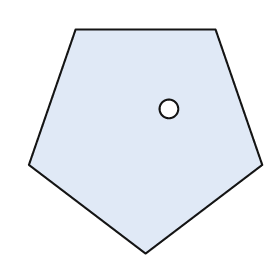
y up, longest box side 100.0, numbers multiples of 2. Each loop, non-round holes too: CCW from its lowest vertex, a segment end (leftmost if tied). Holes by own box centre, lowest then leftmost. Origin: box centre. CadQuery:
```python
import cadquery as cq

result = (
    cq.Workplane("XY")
    .moveTo(0.0, -48.0)
    .lineTo(50.0, -10.0)
    .lineTo(30.0, 48.0)
    .lineTo(-30.0, 48.0)
    .lineTo(-50.0, -10.0)
    .close()
    .moveTo(10.0, 14.0)
    .circle(4.0)
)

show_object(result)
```